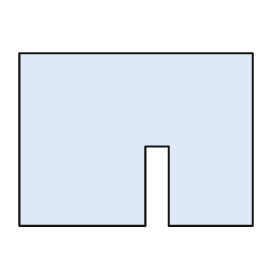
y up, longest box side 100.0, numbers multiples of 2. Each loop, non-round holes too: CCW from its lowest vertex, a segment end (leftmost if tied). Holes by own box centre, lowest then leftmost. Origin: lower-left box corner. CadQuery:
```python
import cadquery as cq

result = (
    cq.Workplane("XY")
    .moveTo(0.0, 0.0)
    .lineTo(54.0, 0.0)
    .lineTo(54.0, 34.0)
    .lineTo(64.0, 34.0)
    .lineTo(64.0, 0.0)
    .lineTo(100.0, 0.0)
    .lineTo(100.0, 74.0)
    .lineTo(0.0, 74.0)
    .close()
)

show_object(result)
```